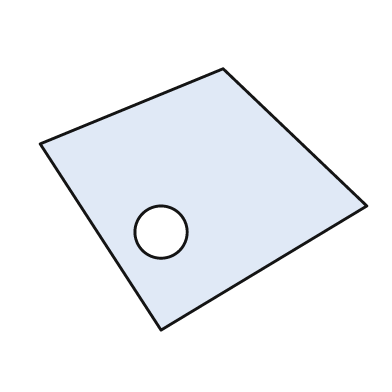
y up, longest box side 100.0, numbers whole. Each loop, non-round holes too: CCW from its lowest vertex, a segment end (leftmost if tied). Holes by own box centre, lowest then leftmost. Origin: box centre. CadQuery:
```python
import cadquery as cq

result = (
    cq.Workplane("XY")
    .moveTo(-13.0, -40.0)
    .lineTo(50.0, -2.0)
    .lineTo(6.0, 40.0)
    .lineTo(-50.0, 17.0)
    .close()
    .moveTo(-13.0, -10.0)
    .circle(8.0)
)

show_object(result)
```